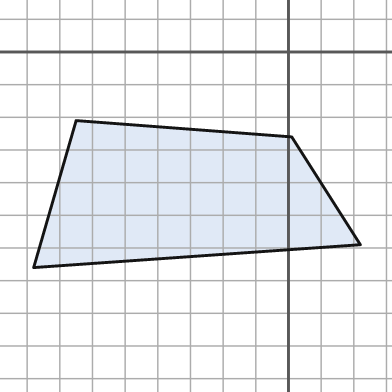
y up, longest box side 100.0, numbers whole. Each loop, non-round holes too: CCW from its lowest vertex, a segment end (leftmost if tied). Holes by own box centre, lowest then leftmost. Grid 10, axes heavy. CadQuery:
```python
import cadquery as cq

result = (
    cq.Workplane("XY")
    .moveTo(-78.0, -66.0)
    .lineTo(22.0, -59.0)
    .lineTo(1.0, -26.0)
    .lineTo(-65.0, -21.0)
    .close()
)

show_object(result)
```